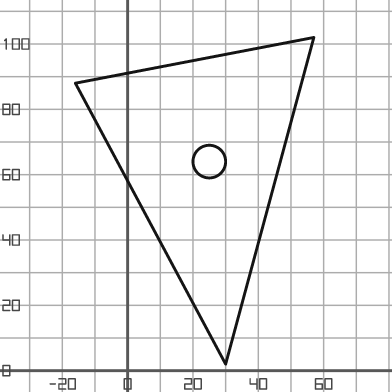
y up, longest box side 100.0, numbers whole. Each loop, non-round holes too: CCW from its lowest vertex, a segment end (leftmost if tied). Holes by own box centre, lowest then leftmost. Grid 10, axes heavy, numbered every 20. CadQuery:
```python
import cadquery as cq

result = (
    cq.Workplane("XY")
    .moveTo(30.0, 2.0)
    .lineTo(57.0, 102.0)
    .lineTo(-16.0, 88.0)
    .close()
    .moveTo(25.0, 64.0)
    .circle(5.0)
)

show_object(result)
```